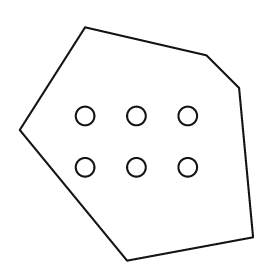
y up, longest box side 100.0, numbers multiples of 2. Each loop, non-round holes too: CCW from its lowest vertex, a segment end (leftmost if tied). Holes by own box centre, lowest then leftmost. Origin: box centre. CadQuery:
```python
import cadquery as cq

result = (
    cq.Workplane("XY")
    .moveTo(-4.0, -50.0)
    .lineTo(50.0, -40.0)
    .lineTo(44.0, 24.0)
    .lineTo(30.0, 38.0)
    .lineTo(-22.0, 50.0)
    .lineTo(-50.0, 6.0)
    .close()
    .moveTo(-22.0, -10.0)
    .circle(4.0)
    .moveTo(0.0, -10.0)
    .circle(4.0)
    .moveTo(22.0, -10.0)
    .circle(4.0)
    .moveTo(-22.0, 12.0)
    .circle(4.0)
    .moveTo(0.0, 12.0)
    .circle(4.0)
    .moveTo(22.0, 12.0)
    .circle(4.0)
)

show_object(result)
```